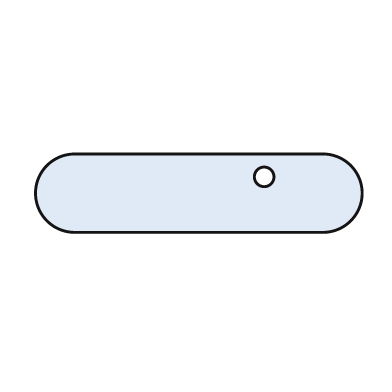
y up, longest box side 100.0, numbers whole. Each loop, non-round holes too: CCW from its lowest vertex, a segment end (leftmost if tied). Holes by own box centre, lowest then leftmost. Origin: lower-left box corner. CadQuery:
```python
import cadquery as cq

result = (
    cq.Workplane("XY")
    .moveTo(12.0, 0.0)
    .lineTo(88.0, 0.0)
    .threePointArc((100.0, 12.0), (88.0, 24.0))
    .lineTo(12.0, 24.0)
    .threePointArc((0.0, 12.0), (12.0, 0.0))
    .close()
    .moveTo(70.0, 17.0)
    .circle(3.0)
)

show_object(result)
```